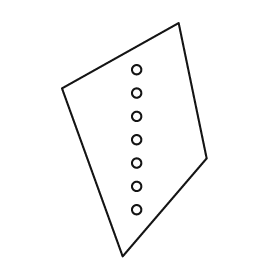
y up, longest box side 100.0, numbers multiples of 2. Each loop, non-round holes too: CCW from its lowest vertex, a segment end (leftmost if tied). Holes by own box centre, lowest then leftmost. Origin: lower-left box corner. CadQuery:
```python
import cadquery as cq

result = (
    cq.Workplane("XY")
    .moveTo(26.0, 0.0)
    .lineTo(62.0, 42.0)
    .lineTo(50.0, 100.0)
    .lineTo(0.0, 72.0)
    .close()
    .moveTo(32.0, 20.0)
    .circle(2.0)
    .moveTo(32.0, 30.0)
    .circle(2.0)
    .moveTo(32.0, 40.0)
    .circle(2.0)
    .moveTo(32.0, 50.0)
    .circle(2.0)
    .moveTo(32.0, 60.0)
    .circle(2.0)
    .moveTo(32.0, 70.0)
    .circle(2.0)
    .moveTo(32.0, 80.0)
    .circle(2.0)
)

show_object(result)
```